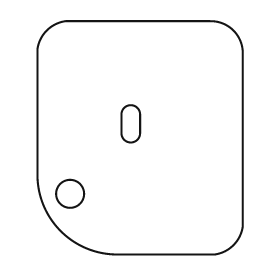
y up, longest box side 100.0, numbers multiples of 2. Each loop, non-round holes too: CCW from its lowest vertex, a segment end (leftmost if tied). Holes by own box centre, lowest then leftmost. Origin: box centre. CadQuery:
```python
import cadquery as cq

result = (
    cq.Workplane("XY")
    .moveTo(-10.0, -50.0)
    .lineTo(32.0, -50.0)
    .threePointArc((40.0, -46.0), (44.0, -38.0))
    .lineTo(44.0, 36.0)
    .threePointArc((40.0, 46.0), (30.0, 50.0))
    .lineTo(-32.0, 50.0)
    .threePointArc((-40.0, 46.0), (-44.0, 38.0))
    .lineTo(-44.0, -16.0)
    .threePointArc((-34.0, -40.0), (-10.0, -50.0))
    .close()
    .moveTo(-30.0, -24.0)
    .circle(6.0)
    .moveTo(-8.0, 2.0)
    .threePointArc((-4.0, -2.0), (0.0, 2.0))
    .lineTo(0.0, 10.0)
    .threePointArc((-4.0, 14.0), (-8.0, 10.0))
    .close()
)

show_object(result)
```